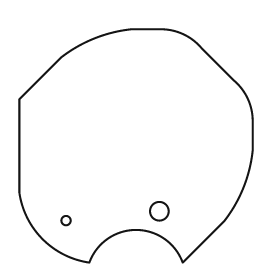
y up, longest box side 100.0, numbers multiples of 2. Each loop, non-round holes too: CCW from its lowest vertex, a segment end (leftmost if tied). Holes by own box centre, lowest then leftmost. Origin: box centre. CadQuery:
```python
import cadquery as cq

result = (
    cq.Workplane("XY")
    .moveTo(-20.0, -50.0)
    .threePointArc((0.0, -36.0), (20.0, -50.0))
    .lineTo(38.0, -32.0)
    .threePointArc((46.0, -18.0), (50.0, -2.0))
    .lineTo(50.0, 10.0)
    .threePointArc((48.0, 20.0), (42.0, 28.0))
    .lineTo(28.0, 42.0)
    .threePointArc((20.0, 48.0), (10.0, 50.0))
    .lineTo(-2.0, 50.0)
    .threePointArc((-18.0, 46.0), (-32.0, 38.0))
    .lineTo(-50.0, 20.0)
    .lineTo(-50.0, -20.0)
    .threePointArc((-40.0, -40.0), (-20.0, -50.0))
    .close()
    .moveTo(-30.0, -32.0)
    .circle(2.0)
    .moveTo(10.0, -28.0)
    .circle(4.0)
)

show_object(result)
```